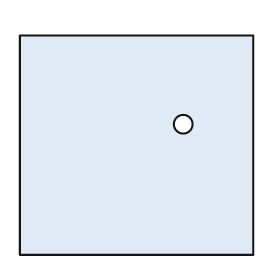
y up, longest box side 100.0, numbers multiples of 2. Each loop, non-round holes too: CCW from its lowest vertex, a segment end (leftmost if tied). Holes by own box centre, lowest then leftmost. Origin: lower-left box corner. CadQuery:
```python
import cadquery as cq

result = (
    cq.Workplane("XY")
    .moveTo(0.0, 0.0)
    .lineTo(100.0, 0.0)
    .lineTo(100.0, 94.0)
    .lineTo(0.0, 94.0)
    .close()
    .moveTo(70.0, 56.0)
    .circle(4.0)
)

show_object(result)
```